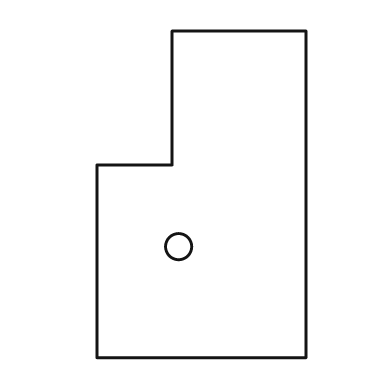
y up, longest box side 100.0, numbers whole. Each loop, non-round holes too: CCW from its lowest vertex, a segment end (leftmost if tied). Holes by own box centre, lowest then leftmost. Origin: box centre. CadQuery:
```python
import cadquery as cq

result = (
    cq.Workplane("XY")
    .moveTo(-32.0, -50.0)
    .lineTo(32.0, -50.0)
    .lineTo(32.0, 50.0)
    .lineTo(-9.0, 50.0)
    .lineTo(-9.0, 9.0)
    .lineTo(-32.0, 9.0)
    .close()
    .moveTo(-7.0, -16.0)
    .circle(4.0)
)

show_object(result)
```